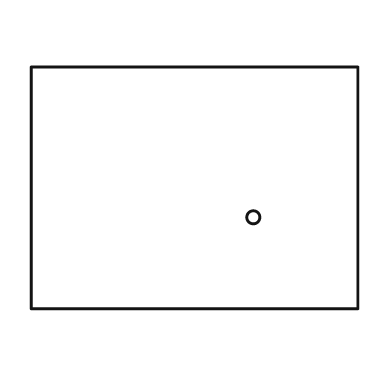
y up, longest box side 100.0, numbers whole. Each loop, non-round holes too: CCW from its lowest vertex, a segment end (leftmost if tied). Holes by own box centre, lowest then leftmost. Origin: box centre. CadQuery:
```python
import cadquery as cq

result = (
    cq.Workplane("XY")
    .moveTo(-50.0, -37.0)
    .lineTo(50.0, -37.0)
    .lineTo(50.0, 37.0)
    .lineTo(-50.0, 37.0)
    .close()
    .moveTo(18.0, -9.0)
    .circle(2.0)
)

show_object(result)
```